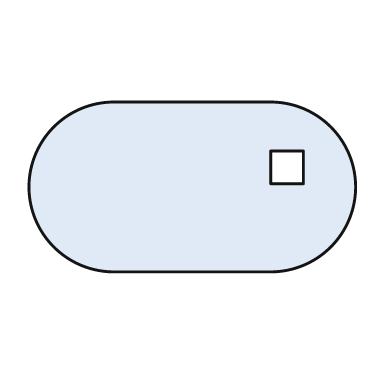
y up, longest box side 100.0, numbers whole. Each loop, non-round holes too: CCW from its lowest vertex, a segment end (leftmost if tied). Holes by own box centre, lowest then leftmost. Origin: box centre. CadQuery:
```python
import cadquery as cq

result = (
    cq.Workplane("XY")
    .moveTo(-24.0, -26.0)
    .lineTo(24.0, -26.0)
    .threePointArc((50.0, 0.0), (24.0, 26.0))
    .lineTo(-24.0, 26.0)
    .threePointArc((-50.0, 0.0), (-24.0, -26.0))
    .close()
    .moveTo(24.0, 1.0)
    .lineTo(34.0, 1.0)
    .lineTo(34.0, 11.0)
    .lineTo(24.0, 11.0)
    .close()
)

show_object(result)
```